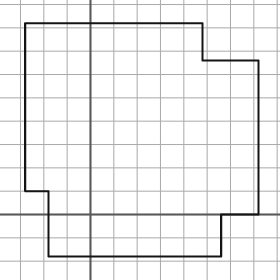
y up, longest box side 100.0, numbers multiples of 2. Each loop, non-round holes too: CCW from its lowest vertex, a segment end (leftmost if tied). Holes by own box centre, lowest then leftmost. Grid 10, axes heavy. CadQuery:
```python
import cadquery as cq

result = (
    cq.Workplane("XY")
    .moveTo(-18.0, -18.0)
    .lineTo(56.0, -18.0)
    .lineTo(56.0, 0.0)
    .lineTo(72.0, 0.0)
    .lineTo(72.0, 66.0)
    .lineTo(48.0, 66.0)
    .lineTo(48.0, 82.0)
    .lineTo(-28.0, 82.0)
    .lineTo(-28.0, 10.0)
    .lineTo(-18.0, 10.0)
    .close()
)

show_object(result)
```